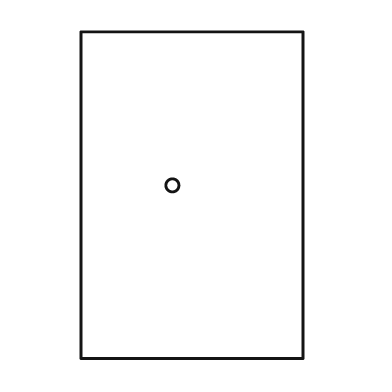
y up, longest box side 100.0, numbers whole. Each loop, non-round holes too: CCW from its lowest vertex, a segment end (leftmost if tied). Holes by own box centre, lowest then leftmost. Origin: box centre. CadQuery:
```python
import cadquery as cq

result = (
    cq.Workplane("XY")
    .moveTo(-34.0, -50.0)
    .lineTo(34.0, -50.0)
    .lineTo(34.0, 50.0)
    .lineTo(-34.0, 50.0)
    .close()
    .moveTo(-6.0, 3.0)
    .circle(2.0)
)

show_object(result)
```